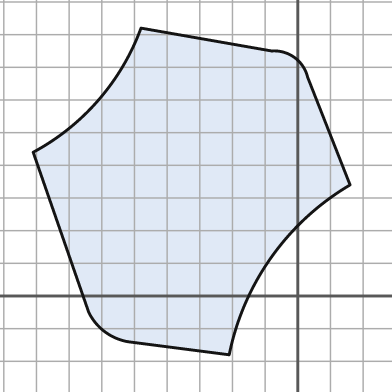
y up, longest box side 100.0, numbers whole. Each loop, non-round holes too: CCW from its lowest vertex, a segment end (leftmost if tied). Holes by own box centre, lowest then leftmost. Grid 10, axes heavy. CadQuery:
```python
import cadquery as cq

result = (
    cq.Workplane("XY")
    .moveTo(-21.0, -18.0)
    .threePointArc((-8.0, 12.0), (16.0, 34.0))
    .lineTo(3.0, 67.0)
    .threePointArc((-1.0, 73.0), (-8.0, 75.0))
    .lineTo(-48.0, 82.0)
    .threePointArc((-61.0, 60.0), (-81.0, 44.0))
    .lineTo(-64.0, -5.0)
    .threePointArc((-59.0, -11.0), (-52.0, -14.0))
    .close()
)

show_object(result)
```